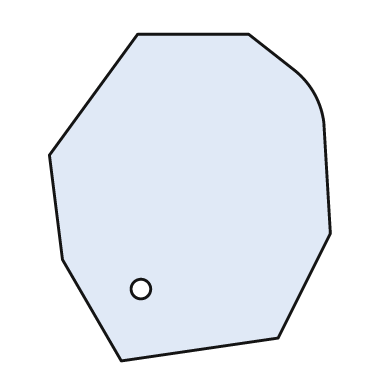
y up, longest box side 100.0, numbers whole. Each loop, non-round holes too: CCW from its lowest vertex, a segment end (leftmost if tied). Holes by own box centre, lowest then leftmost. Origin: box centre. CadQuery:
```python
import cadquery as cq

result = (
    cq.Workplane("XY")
    .moveTo(-21.0, -50.0)
    .lineTo(27.0, -43.0)
    .lineTo(43.0, -11.0)
    .lineTo(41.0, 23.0)
    .threePointArc((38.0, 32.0), (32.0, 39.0))
    .lineTo(18.0, 50.0)
    .lineTo(-16.0, 50.0)
    .lineTo(-43.0, 13.0)
    .lineTo(-39.0, -19.0)
    .close()
    .moveTo(-15.0, -28.0)
    .circle(3.0)
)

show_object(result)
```